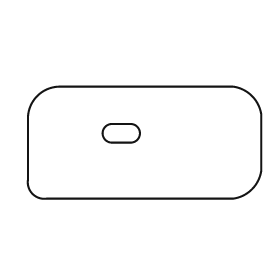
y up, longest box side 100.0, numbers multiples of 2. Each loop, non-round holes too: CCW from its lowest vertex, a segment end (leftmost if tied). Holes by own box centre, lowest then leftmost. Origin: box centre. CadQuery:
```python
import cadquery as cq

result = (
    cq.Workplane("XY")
    .moveTo(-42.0, -24.0)
    .lineTo(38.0, -24.0)
    .threePointArc((46.0, -20.0), (50.0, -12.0))
    .lineTo(50.0, 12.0)
    .threePointArc((46.0, 20.0), (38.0, 24.0))
    .lineTo(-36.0, 24.0)
    .threePointArc((-46.0, 20.0), (-50.0, 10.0))
    .lineTo(-50.0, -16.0)
    .threePointArc((-48.0, -22.0), (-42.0, -24.0))
    .close()
    .moveTo(-14.0, 0.0)
    .lineTo(-6.0, 0.0)
    .threePointArc((-2.0, 4.0), (-6.0, 8.0))
    .lineTo(-14.0, 8.0)
    .threePointArc((-18.0, 4.0), (-14.0, 0.0))
    .close()
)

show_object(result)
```